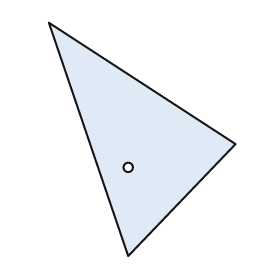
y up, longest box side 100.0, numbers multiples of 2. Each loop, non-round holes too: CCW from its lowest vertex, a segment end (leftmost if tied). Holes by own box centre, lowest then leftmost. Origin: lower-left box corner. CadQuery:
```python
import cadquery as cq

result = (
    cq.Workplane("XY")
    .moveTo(34.0, 0.0)
    .lineTo(80.0, 48.0)
    .lineTo(0.0, 100.0)
    .close()
    .moveTo(34.0, 38.0)
    .circle(2.0)
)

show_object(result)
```